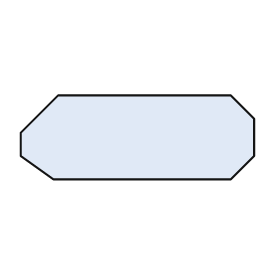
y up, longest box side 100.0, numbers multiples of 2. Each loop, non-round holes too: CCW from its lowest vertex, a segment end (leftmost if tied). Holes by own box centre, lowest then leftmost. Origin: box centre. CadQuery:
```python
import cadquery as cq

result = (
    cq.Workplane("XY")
    .moveTo(-36.0, -18.0)
    .lineTo(40.0, -18.0)
    .lineTo(50.0, -8.0)
    .lineTo(50.0, 8.0)
    .lineTo(40.0, 18.0)
    .lineTo(-34.0, 18.0)
    .lineTo(-50.0, 2.0)
    .lineTo(-50.0, -8.0)
    .close()
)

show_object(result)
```